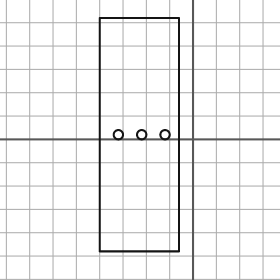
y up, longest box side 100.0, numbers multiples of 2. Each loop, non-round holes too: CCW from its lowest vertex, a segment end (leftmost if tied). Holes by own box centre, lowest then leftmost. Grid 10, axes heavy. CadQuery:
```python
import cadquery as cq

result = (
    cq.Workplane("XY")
    .moveTo(-40.0, -48.0)
    .lineTo(-6.0, -48.0)
    .lineTo(-6.0, 52.0)
    .lineTo(-40.0, 52.0)
    .close()
    .moveTo(-32.0, 2.0)
    .circle(2.0)
    .moveTo(-22.0, 2.0)
    .circle(2.0)
    .moveTo(-12.0, 2.0)
    .circle(2.0)
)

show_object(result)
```